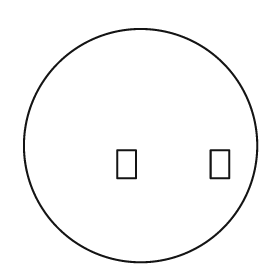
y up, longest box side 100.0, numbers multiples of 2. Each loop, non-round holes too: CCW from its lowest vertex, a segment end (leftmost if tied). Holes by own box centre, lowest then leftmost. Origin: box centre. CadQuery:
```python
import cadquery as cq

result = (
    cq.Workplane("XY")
    .moveTo(0.0, 0.0)
    .circle(50.0)
    .moveTo(-10.0, -14.0)
    .lineTo(-2.0, -14.0)
    .lineTo(-2.0, -2.0)
    .lineTo(-10.0, -2.0)
    .close()
    .moveTo(30.0, -14.0)
    .lineTo(38.0, -14.0)
    .lineTo(38.0, -2.0)
    .lineTo(30.0, -2.0)
    .close()
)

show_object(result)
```